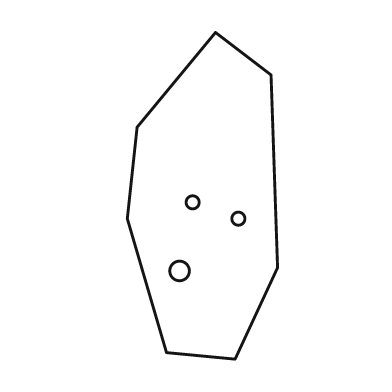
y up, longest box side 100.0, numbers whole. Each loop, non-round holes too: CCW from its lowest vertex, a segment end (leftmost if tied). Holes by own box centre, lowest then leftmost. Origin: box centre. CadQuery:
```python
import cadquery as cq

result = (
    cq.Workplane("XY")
    .moveTo(10.0, -50.0)
    .lineTo(23.0, -22.0)
    .lineTo(21.0, 37.0)
    .lineTo(4.0, 50.0)
    .lineTo(-20.0, 21.0)
    .lineTo(-23.0, -7.0)
    .lineTo(-11.0, -48.0)
    .close()
    .moveTo(-7.0, -23.0)
    .circle(3.0)
    .moveTo(11.0, -7.0)
    .circle(2.0)
    .moveTo(-3.0, -2.0)
    .circle(2.0)
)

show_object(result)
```